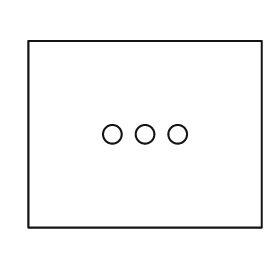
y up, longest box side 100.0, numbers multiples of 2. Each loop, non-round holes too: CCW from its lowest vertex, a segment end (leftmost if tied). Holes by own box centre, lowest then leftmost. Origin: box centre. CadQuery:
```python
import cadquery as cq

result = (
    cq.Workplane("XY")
    .moveTo(-50.0, -40.0)
    .lineTo(50.0, -40.0)
    .lineTo(50.0, 40.0)
    .lineTo(-50.0, 40.0)
    .close()
    .moveTo(-14.0, 0.0)
    .circle(4.0)
    .moveTo(0.0, 0.0)
    .circle(4.0)
    .moveTo(14.0, 0.0)
    .circle(4.0)
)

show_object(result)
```